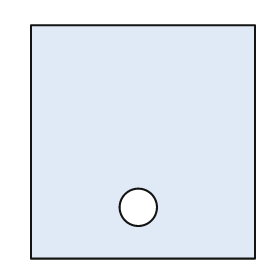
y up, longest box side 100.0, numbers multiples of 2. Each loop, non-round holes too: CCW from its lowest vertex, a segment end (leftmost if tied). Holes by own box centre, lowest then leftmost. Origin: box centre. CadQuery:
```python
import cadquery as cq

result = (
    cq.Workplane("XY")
    .moveTo(-48.0, -50.0)
    .lineTo(48.0, -50.0)
    .lineTo(48.0, 50.0)
    .lineTo(-48.0, 50.0)
    .close()
    .moveTo(-2.0, -28.0)
    .circle(8.0)
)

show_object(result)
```